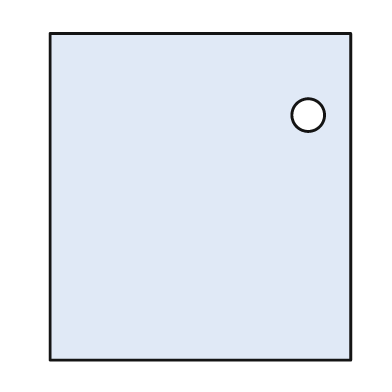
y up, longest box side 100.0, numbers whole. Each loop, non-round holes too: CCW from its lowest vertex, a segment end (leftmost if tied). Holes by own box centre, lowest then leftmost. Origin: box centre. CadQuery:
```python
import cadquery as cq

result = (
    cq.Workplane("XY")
    .moveTo(-46.0, -50.0)
    .lineTo(46.0, -50.0)
    .lineTo(46.0, 50.0)
    .lineTo(-46.0, 50.0)
    .close()
    .moveTo(33.0, 25.0)
    .circle(5.0)
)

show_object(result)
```